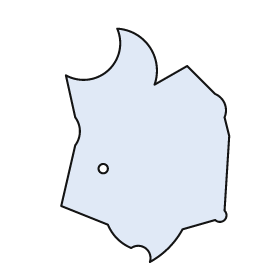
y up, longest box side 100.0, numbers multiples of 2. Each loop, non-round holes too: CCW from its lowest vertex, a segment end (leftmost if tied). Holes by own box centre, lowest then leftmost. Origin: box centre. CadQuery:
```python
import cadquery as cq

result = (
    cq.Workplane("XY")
    .moveTo(2.0, -50.0)
    .threePointArc((10.0, -44.0), (16.0, -36.0))
    .lineTo(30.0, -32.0)
    .threePointArc((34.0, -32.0), (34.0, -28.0))
    .lineTo(36.0, 4.0)
    .lineTo(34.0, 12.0)
    .threePointArc((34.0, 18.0), (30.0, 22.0))
    .lineTo(18.0, 34.0)
    .lineTo(4.0, 26.0)
    .threePointArc((2.0, 42.0), (-12.0, 50.0))
    .threePointArc((-16.0, 32.0), (-34.0, 30.0))
    .lineTo(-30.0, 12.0)
    .threePointArc((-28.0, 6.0), (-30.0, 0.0))
    .lineTo(-36.0, -26.0)
    .lineTo(-16.0, -34.0)
    .threePointArc((-12.0, -40.0), (-6.0, -44.0))
    .threePointArc((0.0, -44.0), (2.0, -50.0))
    .close()
    .moveTo(-18.0, -10.0)
    .circle(2.0)
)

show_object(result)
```